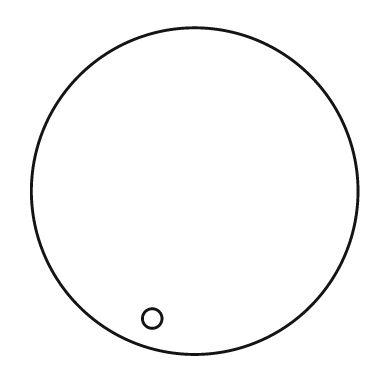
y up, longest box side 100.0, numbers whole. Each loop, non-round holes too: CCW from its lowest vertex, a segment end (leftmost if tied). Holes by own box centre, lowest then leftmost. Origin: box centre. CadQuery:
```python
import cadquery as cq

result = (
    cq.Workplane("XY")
    .moveTo(0.0, 0.0)
    .circle(50.0)
    .moveTo(-13.0, -39.0)
    .circle(3.0)
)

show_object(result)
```